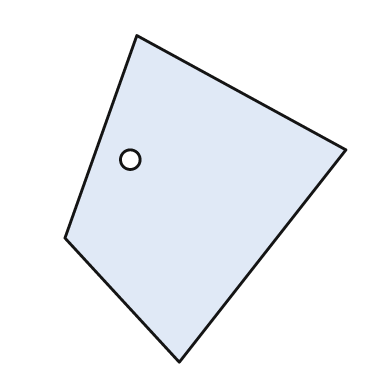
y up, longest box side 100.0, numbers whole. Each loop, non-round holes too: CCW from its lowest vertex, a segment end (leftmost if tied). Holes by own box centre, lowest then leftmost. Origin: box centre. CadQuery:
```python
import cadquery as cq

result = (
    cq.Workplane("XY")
    .moveTo(-8.0, -50.0)
    .lineTo(43.0, 15.0)
    .lineTo(-21.0, 50.0)
    .lineTo(-43.0, -12.0)
    .close()
    .moveTo(-23.0, 12.0)
    .circle(3.0)
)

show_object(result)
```